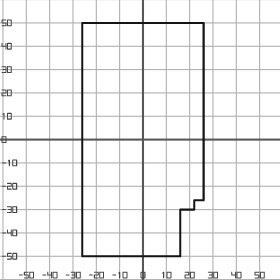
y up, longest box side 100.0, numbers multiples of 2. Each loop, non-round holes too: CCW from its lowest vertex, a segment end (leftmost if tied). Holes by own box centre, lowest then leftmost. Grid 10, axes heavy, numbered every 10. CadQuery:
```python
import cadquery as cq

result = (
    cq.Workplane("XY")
    .moveTo(-26.0, -50.0)
    .lineTo(16.0, -50.0)
    .lineTo(16.0, -30.0)
    .lineTo(22.0, -30.0)
    .lineTo(22.0, -26.0)
    .lineTo(26.0, -26.0)
    .lineTo(26.0, 50.0)
    .lineTo(-26.0, 50.0)
    .close()
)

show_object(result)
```